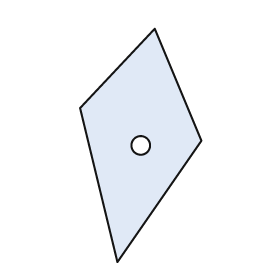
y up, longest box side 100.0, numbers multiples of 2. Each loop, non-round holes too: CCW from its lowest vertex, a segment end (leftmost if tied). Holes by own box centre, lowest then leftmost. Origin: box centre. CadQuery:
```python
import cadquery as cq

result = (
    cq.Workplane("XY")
    .moveTo(-10.0, -50.0)
    .lineTo(26.0, 2.0)
    .lineTo(6.0, 50.0)
    .lineTo(-26.0, 16.0)
    .close()
    .moveTo(0.0, 0.0)
    .circle(4.0)
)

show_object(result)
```